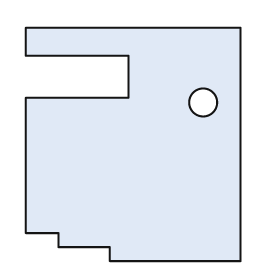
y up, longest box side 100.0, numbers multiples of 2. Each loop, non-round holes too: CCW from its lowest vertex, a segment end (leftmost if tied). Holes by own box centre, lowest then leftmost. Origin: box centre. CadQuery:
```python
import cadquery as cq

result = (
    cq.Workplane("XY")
    .moveTo(-10.0, -50.0)
    .lineTo(46.0, -50.0)
    .lineTo(46.0, 50.0)
    .lineTo(-46.0, 50.0)
    .lineTo(-46.0, 38.0)
    .lineTo(-2.0, 38.0)
    .lineTo(-2.0, 20.0)
    .lineTo(-46.0, 20.0)
    .lineTo(-46.0, -38.0)
    .lineTo(-32.0, -38.0)
    .lineTo(-32.0, -44.0)
    .lineTo(-10.0, -44.0)
    .close()
    .moveTo(30.0, 18.0)
    .circle(6.0)
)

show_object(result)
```